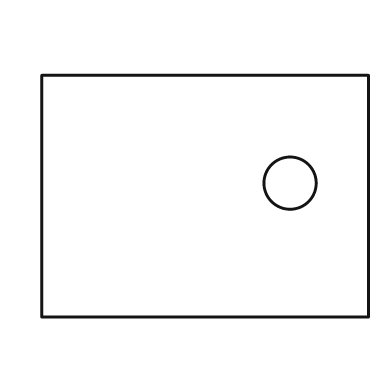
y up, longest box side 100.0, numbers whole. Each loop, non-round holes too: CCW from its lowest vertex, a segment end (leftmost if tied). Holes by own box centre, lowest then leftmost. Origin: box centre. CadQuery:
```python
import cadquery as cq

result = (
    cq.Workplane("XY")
    .moveTo(-50.0, -37.0)
    .lineTo(50.0, -37.0)
    .lineTo(50.0, 37.0)
    .lineTo(-50.0, 37.0)
    .close()
    .moveTo(26.0, 4.0)
    .circle(8.0)
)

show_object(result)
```